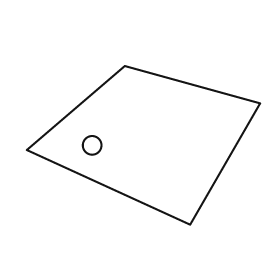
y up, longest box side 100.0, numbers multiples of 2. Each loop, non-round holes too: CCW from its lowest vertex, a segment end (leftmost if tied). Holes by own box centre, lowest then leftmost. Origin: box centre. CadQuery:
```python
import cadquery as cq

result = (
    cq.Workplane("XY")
    .moveTo(20.0, -34.0)
    .lineTo(50.0, 18.0)
    .lineTo(-8.0, 34.0)
    .lineTo(-50.0, -2.0)
    .close()
    .moveTo(-22.0, 0.0)
    .circle(4.0)
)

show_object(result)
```